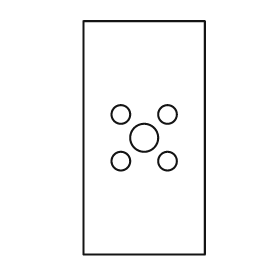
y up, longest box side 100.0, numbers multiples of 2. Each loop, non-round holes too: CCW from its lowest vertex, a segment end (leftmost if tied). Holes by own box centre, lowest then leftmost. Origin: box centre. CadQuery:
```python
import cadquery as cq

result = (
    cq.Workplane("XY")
    .moveTo(-26.0, -50.0)
    .lineTo(26.0, -50.0)
    .lineTo(26.0, 50.0)
    .lineTo(-26.0, 50.0)
    .close()
    .moveTo(-10.0, -10.0)
    .circle(4.0)
    .moveTo(10.0, -10.0)
    .circle(4.0)
    .moveTo(0.0, 0.0)
    .circle(6.0)
    .moveTo(-10.0, 10.0)
    .circle(4.0)
    .moveTo(10.0, 10.0)
    .circle(4.0)
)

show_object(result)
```